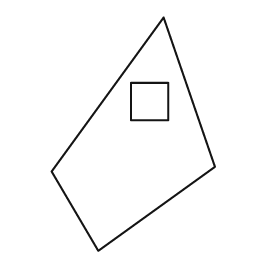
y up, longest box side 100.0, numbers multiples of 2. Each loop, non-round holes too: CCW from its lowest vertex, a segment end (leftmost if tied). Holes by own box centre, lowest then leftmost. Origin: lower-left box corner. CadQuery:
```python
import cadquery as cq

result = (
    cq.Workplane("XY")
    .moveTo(20.0, 0.0)
    .lineTo(70.0, 36.0)
    .lineTo(48.0, 100.0)
    .lineTo(0.0, 34.0)
    .close()
    .moveTo(34.0, 56.0)
    .lineTo(50.0, 56.0)
    .lineTo(50.0, 72.0)
    .lineTo(34.0, 72.0)
    .close()
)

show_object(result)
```